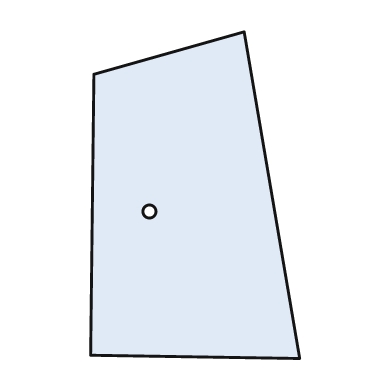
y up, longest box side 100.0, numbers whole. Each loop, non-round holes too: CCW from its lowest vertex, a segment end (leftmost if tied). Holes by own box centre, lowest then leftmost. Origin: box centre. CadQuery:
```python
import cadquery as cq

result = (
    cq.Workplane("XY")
    .moveTo(32.0, -50.0)
    .lineTo(15.0, 50.0)
    .lineTo(-31.0, 37.0)
    .lineTo(-32.0, -49.0)
    .close()
    .moveTo(-14.0, -5.0)
    .circle(2.0)
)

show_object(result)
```